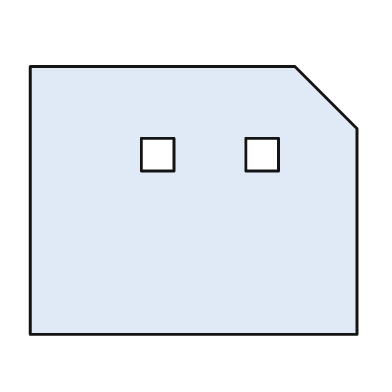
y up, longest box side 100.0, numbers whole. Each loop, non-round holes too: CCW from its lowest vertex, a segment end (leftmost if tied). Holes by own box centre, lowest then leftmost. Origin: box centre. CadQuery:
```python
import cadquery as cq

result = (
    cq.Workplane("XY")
    .moveTo(-50.0, -41.0)
    .lineTo(50.0, -41.0)
    .lineTo(50.0, 22.0)
    .lineTo(31.0, 41.0)
    .lineTo(-50.0, 41.0)
    .close()
    .moveTo(-16.0, 9.0)
    .lineTo(-6.0, 9.0)
    .lineTo(-6.0, 19.0)
    .lineTo(-16.0, 19.0)
    .close()
    .moveTo(16.0, 9.0)
    .lineTo(26.0, 9.0)
    .lineTo(26.0, 19.0)
    .lineTo(16.0, 19.0)
    .close()
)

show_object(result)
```